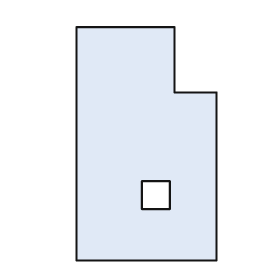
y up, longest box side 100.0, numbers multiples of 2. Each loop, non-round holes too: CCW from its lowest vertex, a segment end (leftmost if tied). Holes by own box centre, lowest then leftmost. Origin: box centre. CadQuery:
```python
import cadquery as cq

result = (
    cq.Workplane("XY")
    .moveTo(-30.0, -50.0)
    .lineTo(30.0, -50.0)
    .lineTo(30.0, 22.0)
    .lineTo(12.0, 22.0)
    .lineTo(12.0, 50.0)
    .lineTo(-30.0, 50.0)
    .close()
    .moveTo(-2.0, -28.0)
    .lineTo(10.0, -28.0)
    .lineTo(10.0, -16.0)
    .lineTo(-2.0, -16.0)
    .close()
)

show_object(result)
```